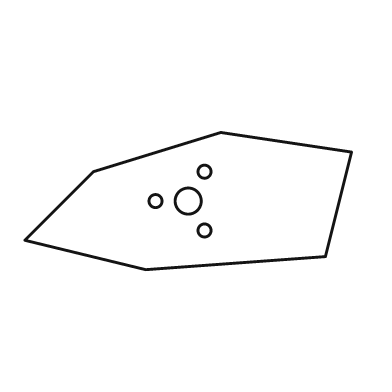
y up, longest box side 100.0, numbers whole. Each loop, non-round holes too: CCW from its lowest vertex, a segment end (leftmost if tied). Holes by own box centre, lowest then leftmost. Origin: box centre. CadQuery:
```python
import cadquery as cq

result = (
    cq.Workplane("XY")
    .moveTo(-13.0, -21.0)
    .lineTo(42.0, -17.0)
    .lineTo(50.0, 15.0)
    .lineTo(10.0, 21.0)
    .lineTo(-29.0, 9.0)
    .lineTo(-50.0, -12.0)
    .close()
    .moveTo(5.0, -9.0)
    .circle(2.0)
    .moveTo(-10.0, 0.0)
    .circle(2.0)
    .moveTo(0.0, 0.0)
    .circle(4.0)
    .moveTo(5.0, 9.0)
    .circle(2.0)
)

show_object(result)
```